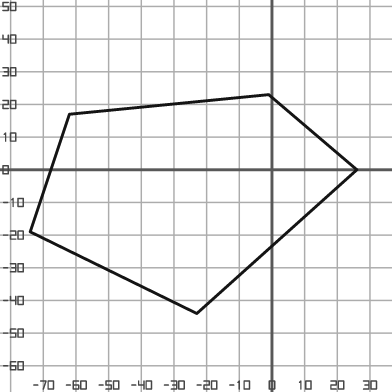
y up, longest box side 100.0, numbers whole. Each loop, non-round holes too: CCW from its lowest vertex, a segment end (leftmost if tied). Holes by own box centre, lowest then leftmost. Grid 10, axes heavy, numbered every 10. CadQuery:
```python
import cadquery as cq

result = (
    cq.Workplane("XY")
    .moveTo(-23.0, -44.0)
    .lineTo(26.0, 0.0)
    .lineTo(-1.0, 23.0)
    .lineTo(-62.0, 17.0)
    .lineTo(-74.0, -19.0)
    .close()
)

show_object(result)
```